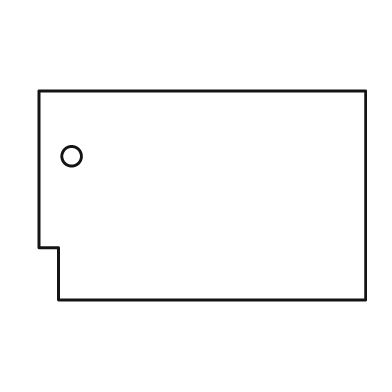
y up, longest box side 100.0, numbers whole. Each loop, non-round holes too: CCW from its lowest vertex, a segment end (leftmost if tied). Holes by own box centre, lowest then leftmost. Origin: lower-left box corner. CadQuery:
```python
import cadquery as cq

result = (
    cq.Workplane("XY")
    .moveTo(6.0, 0.0)
    .lineTo(100.0, 0.0)
    .lineTo(100.0, 64.0)
    .lineTo(0.0, 64.0)
    .lineTo(0.0, 16.0)
    .lineTo(6.0, 16.0)
    .close()
    .moveTo(10.0, 44.0)
    .circle(3.0)
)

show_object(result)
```